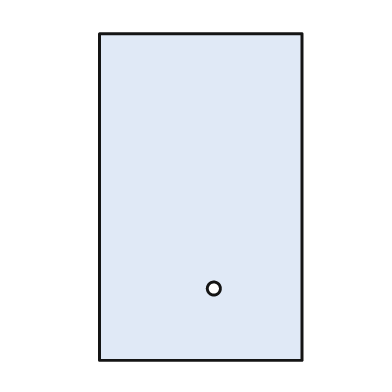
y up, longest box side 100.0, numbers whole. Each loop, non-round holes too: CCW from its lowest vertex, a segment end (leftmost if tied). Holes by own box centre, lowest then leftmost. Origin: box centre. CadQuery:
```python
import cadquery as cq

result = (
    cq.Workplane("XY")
    .moveTo(-31.0, -50.0)
    .lineTo(31.0, -50.0)
    .lineTo(31.0, 50.0)
    .lineTo(-31.0, 50.0)
    .close()
    .moveTo(4.0, -28.0)
    .circle(2.0)
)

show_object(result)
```